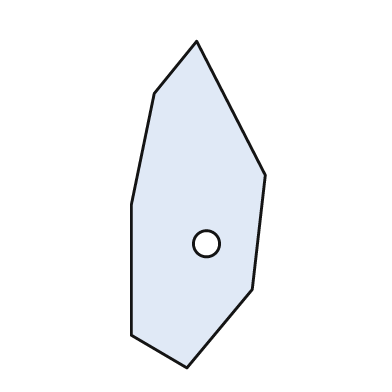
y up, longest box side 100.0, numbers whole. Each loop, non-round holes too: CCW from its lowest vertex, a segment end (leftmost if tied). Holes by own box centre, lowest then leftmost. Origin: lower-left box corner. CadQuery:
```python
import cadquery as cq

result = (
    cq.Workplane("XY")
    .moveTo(17.0, 0.0)
    .lineTo(37.0, 24.0)
    .lineTo(41.0, 59.0)
    .lineTo(20.0, 100.0)
    .lineTo(7.0, 84.0)
    .lineTo(0.0, 50.0)
    .lineTo(0.0, 10.0)
    .close()
    .moveTo(23.0, 38.0)
    .circle(4.0)
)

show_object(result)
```